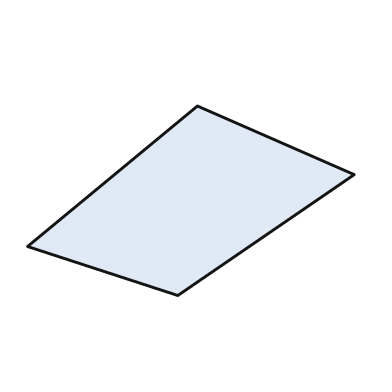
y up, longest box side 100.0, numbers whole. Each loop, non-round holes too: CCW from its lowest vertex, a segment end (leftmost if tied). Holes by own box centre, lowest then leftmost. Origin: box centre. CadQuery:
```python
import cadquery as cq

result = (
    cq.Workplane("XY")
    .moveTo(-4.0, -29.0)
    .lineTo(50.0, 8.0)
    .lineTo(2.0, 29.0)
    .lineTo(-50.0, -14.0)
    .close()
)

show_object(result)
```